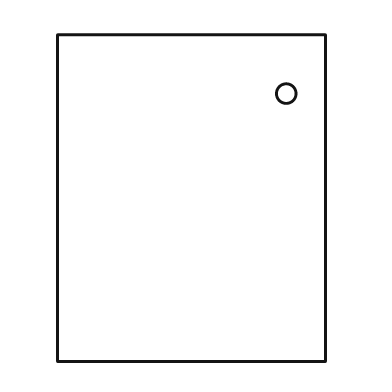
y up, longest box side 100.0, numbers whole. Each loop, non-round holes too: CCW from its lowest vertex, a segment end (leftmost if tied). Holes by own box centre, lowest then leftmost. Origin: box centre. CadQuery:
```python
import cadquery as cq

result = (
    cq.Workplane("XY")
    .moveTo(-41.0, -50.0)
    .lineTo(41.0, -50.0)
    .lineTo(41.0, 50.0)
    .lineTo(-41.0, 50.0)
    .close()
    .moveTo(29.0, 32.0)
    .circle(3.0)
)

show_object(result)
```